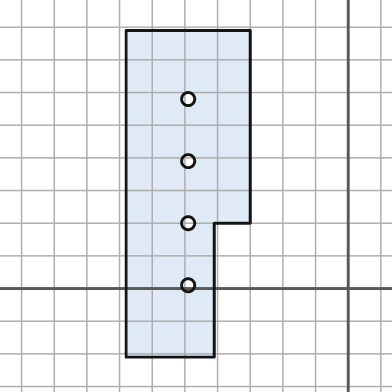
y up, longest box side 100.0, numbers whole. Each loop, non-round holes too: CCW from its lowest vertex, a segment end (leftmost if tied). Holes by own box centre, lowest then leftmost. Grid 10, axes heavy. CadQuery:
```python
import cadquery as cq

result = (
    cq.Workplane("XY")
    .moveTo(-68.0, -21.0)
    .lineTo(-41.0, -21.0)
    .lineTo(-41.0, 20.0)
    .lineTo(-30.0, 20.0)
    .lineTo(-30.0, 79.0)
    .lineTo(-68.0, 79.0)
    .close()
    .moveTo(-49.0, 1.0)
    .circle(2.0)
    .moveTo(-49.0, 20.0)
    .circle(2.0)
    .moveTo(-49.0, 39.0)
    .circle(2.0)
    .moveTo(-49.0, 58.0)
    .circle(2.0)
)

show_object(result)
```